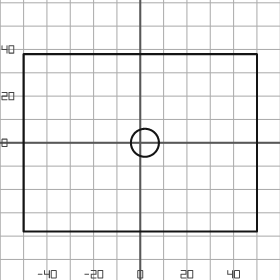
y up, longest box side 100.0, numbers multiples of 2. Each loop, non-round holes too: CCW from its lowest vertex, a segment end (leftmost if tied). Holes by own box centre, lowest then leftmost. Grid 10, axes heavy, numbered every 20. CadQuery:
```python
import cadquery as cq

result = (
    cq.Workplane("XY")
    .moveTo(-50.0, -38.0)
    .lineTo(50.0, -38.0)
    .lineTo(50.0, 38.0)
    .lineTo(-50.0, 38.0)
    .close()
    .moveTo(2.0, 0.0)
    .circle(6.0)
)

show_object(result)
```